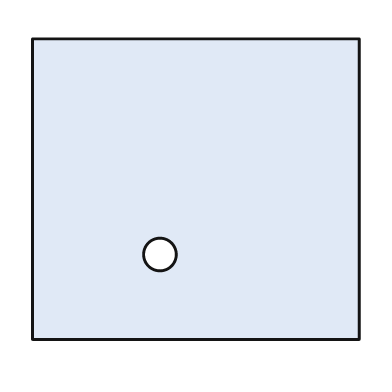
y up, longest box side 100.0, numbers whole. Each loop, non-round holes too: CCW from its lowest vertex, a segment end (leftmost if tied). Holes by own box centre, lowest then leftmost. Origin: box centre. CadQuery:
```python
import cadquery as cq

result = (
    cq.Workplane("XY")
    .moveTo(-50.0, -46.0)
    .lineTo(50.0, -46.0)
    .lineTo(50.0, 46.0)
    .lineTo(-50.0, 46.0)
    .close()
    .moveTo(-11.0, -20.0)
    .circle(5.0)
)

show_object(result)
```